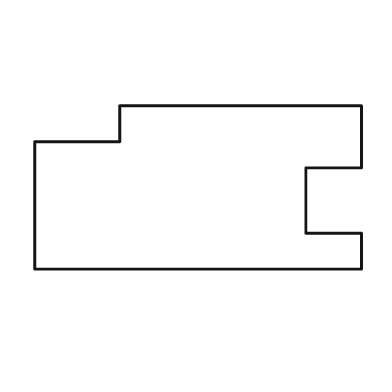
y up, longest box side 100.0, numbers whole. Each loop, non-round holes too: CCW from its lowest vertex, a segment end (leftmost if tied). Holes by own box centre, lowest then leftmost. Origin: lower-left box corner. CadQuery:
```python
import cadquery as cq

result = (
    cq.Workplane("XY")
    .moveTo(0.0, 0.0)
    .lineTo(100.0, 0.0)
    .lineTo(100.0, 11.0)
    .lineTo(83.0, 11.0)
    .lineTo(83.0, 31.0)
    .lineTo(100.0, 31.0)
    .lineTo(100.0, 50.0)
    .lineTo(26.0, 50.0)
    .lineTo(26.0, 39.0)
    .lineTo(0.0, 39.0)
    .close()
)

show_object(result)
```